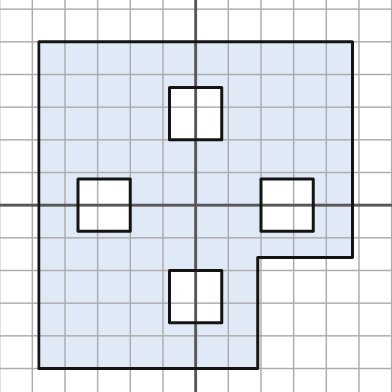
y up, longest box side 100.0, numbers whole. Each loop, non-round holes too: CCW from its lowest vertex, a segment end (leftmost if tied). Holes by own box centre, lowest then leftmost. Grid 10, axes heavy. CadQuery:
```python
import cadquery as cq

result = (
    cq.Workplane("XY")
    .moveTo(-48.0, -50.0)
    .lineTo(19.0, -50.0)
    .lineTo(19.0, -16.0)
    .lineTo(48.0, -16.0)
    .lineTo(48.0, 50.0)
    .lineTo(-48.0, 50.0)
    .close()
    .moveTo(-8.0, -36.0)
    .lineTo(8.0, -36.0)
    .lineTo(8.0, -20.0)
    .lineTo(-8.0, -20.0)
    .close()
    .moveTo(-36.0, -8.0)
    .lineTo(-20.0, -8.0)
    .lineTo(-20.0, 8.0)
    .lineTo(-36.0, 8.0)
    .close()
    .moveTo(20.0, -8.0)
    .lineTo(36.0, -8.0)
    .lineTo(36.0, 8.0)
    .lineTo(20.0, 8.0)
    .close()
    .moveTo(-8.0, 20.0)
    .lineTo(8.0, 20.0)
    .lineTo(8.0, 36.0)
    .lineTo(-8.0, 36.0)
    .close()
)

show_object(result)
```